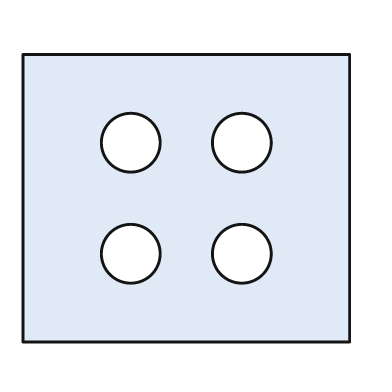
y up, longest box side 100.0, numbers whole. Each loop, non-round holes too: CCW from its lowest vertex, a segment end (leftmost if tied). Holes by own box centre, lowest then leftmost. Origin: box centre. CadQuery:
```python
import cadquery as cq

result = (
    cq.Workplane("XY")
    .moveTo(-50.0, -44.0)
    .lineTo(50.0, -44.0)
    .lineTo(50.0, 44.0)
    .lineTo(-50.0, 44.0)
    .close()
    .moveTo(-17.0, -17.0)
    .circle(9.0)
    .moveTo(17.0, -17.0)
    .circle(9.0)
    .moveTo(-17.0, 17.0)
    .circle(9.0)
    .moveTo(17.0, 17.0)
    .circle(9.0)
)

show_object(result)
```